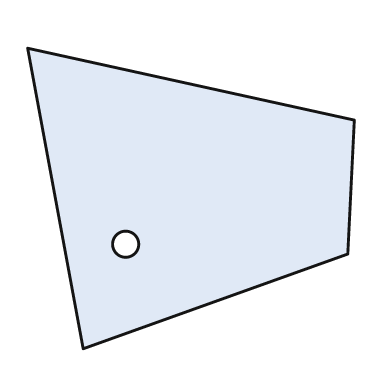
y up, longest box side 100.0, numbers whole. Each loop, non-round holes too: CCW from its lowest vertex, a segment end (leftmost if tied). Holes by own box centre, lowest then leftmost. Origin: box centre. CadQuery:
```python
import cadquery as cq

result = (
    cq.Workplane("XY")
    .moveTo(-33.0, -46.0)
    .lineTo(48.0, -17.0)
    .lineTo(50.0, 24.0)
    .lineTo(-50.0, 46.0)
    .close()
    .moveTo(-20.0, -14.0)
    .circle(4.0)
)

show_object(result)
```